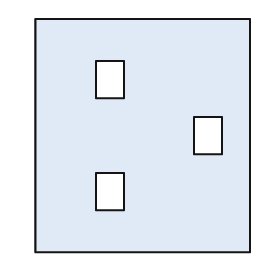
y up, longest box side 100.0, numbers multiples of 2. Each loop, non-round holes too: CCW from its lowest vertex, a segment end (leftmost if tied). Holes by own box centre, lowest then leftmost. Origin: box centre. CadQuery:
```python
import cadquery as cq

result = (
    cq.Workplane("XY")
    .moveTo(-46.0, -50.0)
    .lineTo(46.0, -50.0)
    .lineTo(46.0, 50.0)
    .lineTo(-46.0, 50.0)
    .close()
    .moveTo(-20.0, -32.0)
    .lineTo(-8.0, -32.0)
    .lineTo(-8.0, -16.0)
    .lineTo(-20.0, -16.0)
    .close()
    .moveTo(22.0, -8.0)
    .lineTo(34.0, -8.0)
    .lineTo(34.0, 8.0)
    .lineTo(22.0, 8.0)
    .close()
    .moveTo(-20.0, 16.0)
    .lineTo(-8.0, 16.0)
    .lineTo(-8.0, 32.0)
    .lineTo(-20.0, 32.0)
    .close()
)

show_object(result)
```